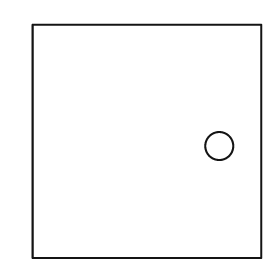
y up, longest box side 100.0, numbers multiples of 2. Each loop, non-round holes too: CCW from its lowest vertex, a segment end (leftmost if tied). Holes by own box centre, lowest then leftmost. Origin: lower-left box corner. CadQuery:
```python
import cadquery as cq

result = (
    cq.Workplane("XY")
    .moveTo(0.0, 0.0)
    .lineTo(98.0, 0.0)
    .lineTo(98.0, 100.0)
    .lineTo(0.0, 100.0)
    .close()
    .moveTo(80.0, 48.0)
    .circle(6.0)
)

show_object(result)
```